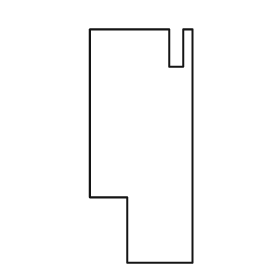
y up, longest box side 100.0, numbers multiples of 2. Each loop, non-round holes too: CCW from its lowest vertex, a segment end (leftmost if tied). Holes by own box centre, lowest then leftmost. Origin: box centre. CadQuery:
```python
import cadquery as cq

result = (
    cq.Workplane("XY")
    .moveTo(-6.0, -50.0)
    .lineTo(22.0, -50.0)
    .lineTo(22.0, 50.0)
    .lineTo(18.0, 50.0)
    .lineTo(18.0, 34.0)
    .lineTo(12.0, 34.0)
    .lineTo(12.0, 50.0)
    .lineTo(-22.0, 50.0)
    .lineTo(-22.0, -22.0)
    .lineTo(-6.0, -22.0)
    .close()
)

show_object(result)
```